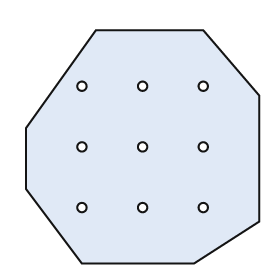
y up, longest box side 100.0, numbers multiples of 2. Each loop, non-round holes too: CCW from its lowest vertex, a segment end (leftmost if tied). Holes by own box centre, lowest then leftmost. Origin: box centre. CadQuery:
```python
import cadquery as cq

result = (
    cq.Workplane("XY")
    .moveTo(-26.0, -50.0)
    .lineTo(22.0, -50.0)
    .lineTo(50.0, -32.0)
    .lineTo(50.0, 22.0)
    .lineTo(26.0, 50.0)
    .lineTo(-20.0, 50.0)
    .lineTo(-50.0, 8.0)
    .lineTo(-50.0, -18.0)
    .close()
    .moveTo(-26.0, -26.0)
    .circle(2.0)
    .moveTo(0.0, -26.0)
    .circle(2.0)
    .moveTo(26.0, -26.0)
    .circle(2.0)
    .moveTo(-26.0, 0.0)
    .circle(2.0)
    .moveTo(0.0, 0.0)
    .circle(2.0)
    .moveTo(26.0, 0.0)
    .circle(2.0)
    .moveTo(-26.0, 26.0)
    .circle(2.0)
    .moveTo(0.0, 26.0)
    .circle(2.0)
    .moveTo(26.0, 26.0)
    .circle(2.0)
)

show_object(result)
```